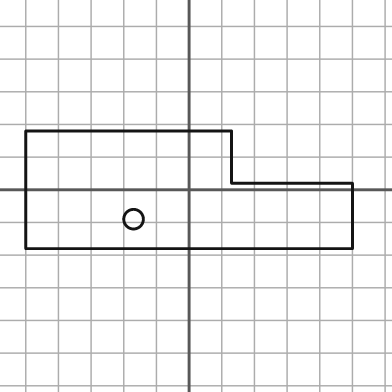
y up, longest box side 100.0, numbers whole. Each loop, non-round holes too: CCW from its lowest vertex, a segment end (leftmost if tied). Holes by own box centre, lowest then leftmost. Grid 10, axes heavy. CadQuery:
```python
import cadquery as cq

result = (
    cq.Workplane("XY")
    .moveTo(-50.0, -18.0)
    .lineTo(50.0, -18.0)
    .lineTo(50.0, 2.0)
    .lineTo(13.0, 2.0)
    .lineTo(13.0, 18.0)
    .lineTo(-50.0, 18.0)
    .close()
    .moveTo(-17.0, -9.0)
    .circle(3.0)
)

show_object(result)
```